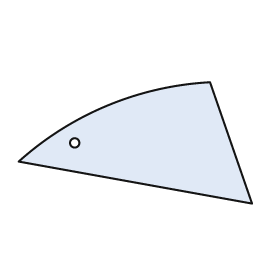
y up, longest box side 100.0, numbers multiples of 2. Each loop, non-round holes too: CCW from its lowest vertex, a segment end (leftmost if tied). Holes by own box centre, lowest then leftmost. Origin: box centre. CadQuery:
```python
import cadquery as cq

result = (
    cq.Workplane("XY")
    .moveTo(50.0, -26.0)
    .lineTo(32.0, 26.0)
    .threePointArc((-12.0, 16.0), (-50.0, -8.0))
    .close()
    .moveTo(-26.0, 0.0)
    .circle(2.0)
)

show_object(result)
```